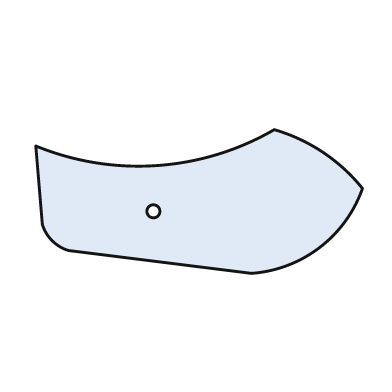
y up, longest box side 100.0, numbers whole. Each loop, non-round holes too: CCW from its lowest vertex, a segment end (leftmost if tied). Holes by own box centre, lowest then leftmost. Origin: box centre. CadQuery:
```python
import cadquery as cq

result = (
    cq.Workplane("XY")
    .moveTo(16.0, -22.0)
    .threePointArc((37.0, -14.0), (50.0, 4.0))
    .threePointArc((38.0, 15.0), (23.0, 22.0))
    .threePointArc((-13.0, 11.0), (-50.0, 17.0))
    .lineTo(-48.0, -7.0)
    .threePointArc((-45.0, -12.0), (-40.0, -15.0))
    .close()
    .moveTo(-14.0, -3.0)
    .circle(2.0)
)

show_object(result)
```